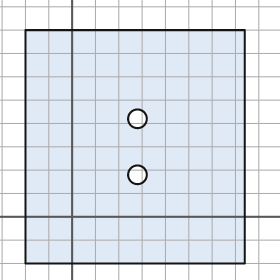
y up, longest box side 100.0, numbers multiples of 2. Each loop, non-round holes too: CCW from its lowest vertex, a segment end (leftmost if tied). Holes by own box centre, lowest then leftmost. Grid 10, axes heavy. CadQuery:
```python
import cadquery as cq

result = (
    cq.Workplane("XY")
    .moveTo(-20.0, -20.0)
    .lineTo(74.0, -20.0)
    .lineTo(74.0, 80.0)
    .lineTo(-20.0, 80.0)
    .close()
    .moveTo(28.0, 18.0)
    .circle(4.0)
    .moveTo(28.0, 42.0)
    .circle(4.0)
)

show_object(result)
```